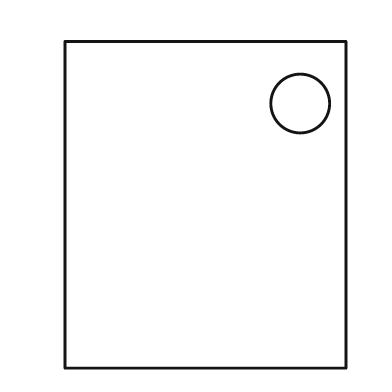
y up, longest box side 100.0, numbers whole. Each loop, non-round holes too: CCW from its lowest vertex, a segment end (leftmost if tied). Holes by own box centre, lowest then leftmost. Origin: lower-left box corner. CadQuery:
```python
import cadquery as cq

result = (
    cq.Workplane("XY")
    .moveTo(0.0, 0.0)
    .lineTo(86.0, 0.0)
    .lineTo(86.0, 100.0)
    .lineTo(0.0, 100.0)
    .close()
    .moveTo(72.0, 81.0)
    .circle(9.0)
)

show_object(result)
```